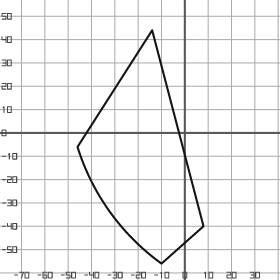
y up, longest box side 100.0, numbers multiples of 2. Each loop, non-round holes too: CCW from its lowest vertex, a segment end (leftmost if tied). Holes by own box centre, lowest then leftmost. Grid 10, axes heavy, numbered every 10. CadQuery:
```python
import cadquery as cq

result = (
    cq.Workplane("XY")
    .moveTo(-10.0, -56.0)
    .lineTo(8.0, -40.0)
    .lineTo(-14.0, 44.0)
    .lineTo(-46.0, -6.0)
    .threePointArc((-32.0, -34.0), (-10.0, -56.0))
    .close()
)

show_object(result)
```